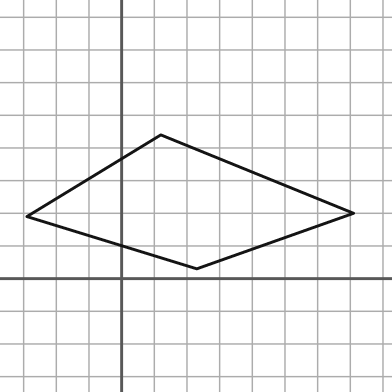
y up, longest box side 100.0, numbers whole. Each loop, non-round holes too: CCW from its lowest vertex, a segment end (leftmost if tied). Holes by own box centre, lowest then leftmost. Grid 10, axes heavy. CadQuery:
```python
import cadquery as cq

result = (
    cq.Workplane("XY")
    .moveTo(23.0, 3.0)
    .lineTo(71.0, 20.0)
    .lineTo(12.0, 44.0)
    .lineTo(-29.0, 19.0)
    .close()
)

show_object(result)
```